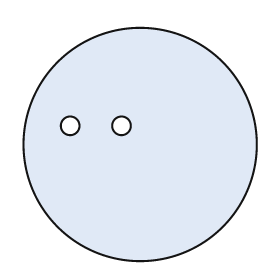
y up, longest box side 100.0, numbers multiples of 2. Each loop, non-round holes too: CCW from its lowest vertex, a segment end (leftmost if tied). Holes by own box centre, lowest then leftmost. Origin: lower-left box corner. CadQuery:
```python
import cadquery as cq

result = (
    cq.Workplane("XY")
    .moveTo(50.0, 50.0)
    .circle(50.0)
    .moveTo(20.0, 58.0)
    .circle(4.0)
    .moveTo(42.0, 58.0)
    .circle(4.0)
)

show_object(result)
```